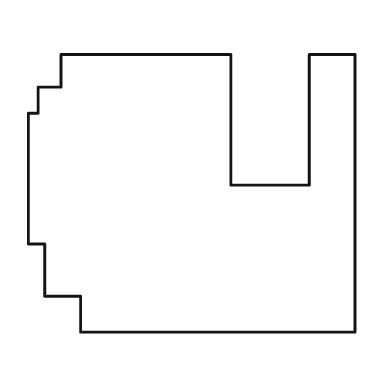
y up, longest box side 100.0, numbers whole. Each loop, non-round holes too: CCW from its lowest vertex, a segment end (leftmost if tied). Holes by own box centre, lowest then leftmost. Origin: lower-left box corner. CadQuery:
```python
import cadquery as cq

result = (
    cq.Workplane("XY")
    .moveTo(16.0, 0.0)
    .lineTo(100.0, 0.0)
    .lineTo(100.0, 85.0)
    .lineTo(86.0, 85.0)
    .lineTo(86.0, 45.0)
    .lineTo(62.0, 45.0)
    .lineTo(62.0, 85.0)
    .lineTo(10.0, 85.0)
    .lineTo(10.0, 75.0)
    .lineTo(3.0, 75.0)
    .lineTo(3.0, 67.0)
    .lineTo(0.0, 67.0)
    .lineTo(0.0, 27.0)
    .lineTo(5.0, 27.0)
    .lineTo(5.0, 11.0)
    .lineTo(16.0, 11.0)
    .close()
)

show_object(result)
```